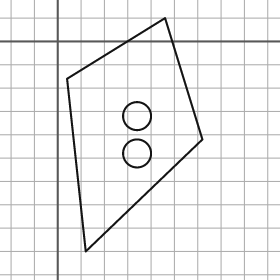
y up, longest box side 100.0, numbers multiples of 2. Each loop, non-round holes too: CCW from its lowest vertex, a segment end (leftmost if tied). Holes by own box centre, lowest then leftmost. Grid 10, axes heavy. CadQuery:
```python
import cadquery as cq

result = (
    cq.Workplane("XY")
    .moveTo(12.0, -90.0)
    .lineTo(62.0, -42.0)
    .lineTo(46.0, 10.0)
    .lineTo(4.0, -16.0)
    .close()
    .moveTo(34.0, -48.0)
    .circle(6.0)
    .moveTo(34.0, -32.0)
    .circle(6.0)
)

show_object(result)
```